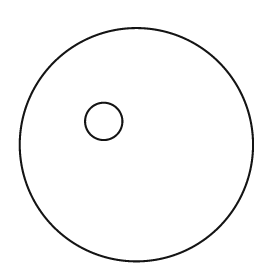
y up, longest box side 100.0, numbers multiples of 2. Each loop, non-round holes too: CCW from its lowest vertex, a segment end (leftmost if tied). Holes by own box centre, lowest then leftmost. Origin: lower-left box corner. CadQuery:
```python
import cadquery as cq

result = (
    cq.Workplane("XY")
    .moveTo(50.0, 50.0)
    .circle(50.0)
    .moveTo(36.0, 60.0)
    .circle(8.0)
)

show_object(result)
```